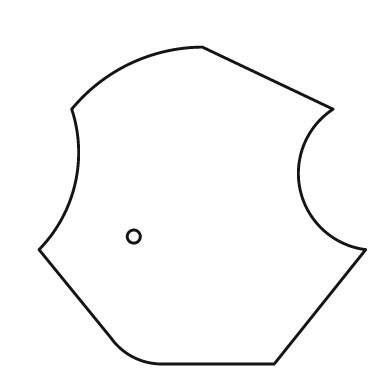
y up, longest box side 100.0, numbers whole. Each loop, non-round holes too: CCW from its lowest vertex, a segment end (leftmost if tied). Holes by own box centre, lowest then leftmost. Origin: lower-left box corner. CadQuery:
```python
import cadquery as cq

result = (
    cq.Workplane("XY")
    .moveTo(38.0, 0.0)
    .lineTo(72.0, 0.0)
    .lineTo(100.0, 35.0)
    .threePointArc((80.0, 53.0), (90.0, 78.0))
    .lineTo(50.0, 97.0)
    .threePointArc((28.0, 92.0), (10.0, 78.0))
    .threePointArc((11.0, 55.0), (0.0, 35.0))
    .lineTo(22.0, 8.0)
    .threePointArc((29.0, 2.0), (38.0, 0.0))
    .close()
    .moveTo(29.0, 39.0)
    .circle(2.0)
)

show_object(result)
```